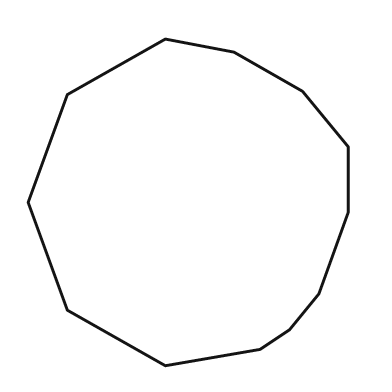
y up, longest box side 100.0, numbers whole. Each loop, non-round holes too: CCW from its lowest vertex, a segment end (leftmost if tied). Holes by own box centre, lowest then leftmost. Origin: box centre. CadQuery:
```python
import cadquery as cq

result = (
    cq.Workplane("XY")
    .moveTo(-7.0, -50.0)
    .lineTo(22.0, -45.0)
    .lineTo(31.0, -39.0)
    .lineTo(40.0, -28.0)
    .lineTo(49.0, -3.0)
    .lineTo(49.0, 17.0)
    .lineTo(35.0, 34.0)
    .lineTo(14.0, 46.0)
    .lineTo(-7.0, 50.0)
    .lineTo(-37.0, 33.0)
    .lineTo(-49.0, 0.0)
    .lineTo(-37.0, -33.0)
    .close()
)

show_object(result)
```